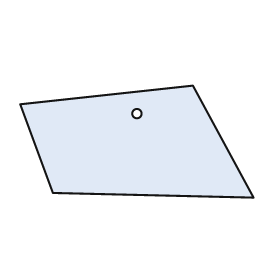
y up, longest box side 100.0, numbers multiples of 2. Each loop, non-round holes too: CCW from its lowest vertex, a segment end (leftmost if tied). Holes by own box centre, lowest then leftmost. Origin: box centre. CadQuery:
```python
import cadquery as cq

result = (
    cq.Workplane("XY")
    .moveTo(50.0, -24.0)
    .lineTo(24.0, 24.0)
    .lineTo(-50.0, 16.0)
    .lineTo(-36.0, -22.0)
    .close()
    .moveTo(0.0, 12.0)
    .circle(2.0)
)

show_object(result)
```